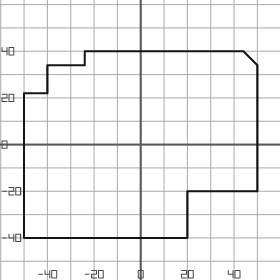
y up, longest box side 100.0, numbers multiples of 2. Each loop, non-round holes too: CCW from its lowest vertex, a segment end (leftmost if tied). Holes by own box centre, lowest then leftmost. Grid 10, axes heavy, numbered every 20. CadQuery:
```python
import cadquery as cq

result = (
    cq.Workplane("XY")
    .moveTo(-50.0, -40.0)
    .lineTo(20.0, -40.0)
    .lineTo(20.0, -20.0)
    .lineTo(50.0, -20.0)
    .lineTo(50.0, 34.0)
    .lineTo(44.0, 40.0)
    .lineTo(-24.0, 40.0)
    .lineTo(-24.0, 34.0)
    .lineTo(-40.0, 34.0)
    .lineTo(-40.0, 22.0)
    .lineTo(-50.0, 22.0)
    .close()
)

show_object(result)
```